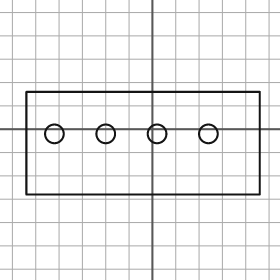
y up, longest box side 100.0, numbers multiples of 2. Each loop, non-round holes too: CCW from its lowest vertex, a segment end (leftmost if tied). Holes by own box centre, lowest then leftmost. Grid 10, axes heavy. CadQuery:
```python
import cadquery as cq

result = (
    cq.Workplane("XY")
    .moveTo(-54.0, -28.0)
    .lineTo(46.0, -28.0)
    .lineTo(46.0, 16.0)
    .lineTo(-54.0, 16.0)
    .close()
    .moveTo(-42.0, -2.0)
    .circle(4.0)
    .moveTo(-20.0, -2.0)
    .circle(4.0)
    .moveTo(2.0, -2.0)
    .circle(4.0)
    .moveTo(24.0, -2.0)
    .circle(4.0)
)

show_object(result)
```